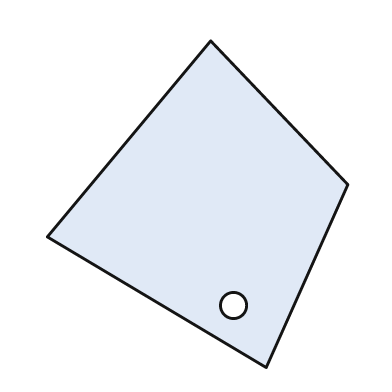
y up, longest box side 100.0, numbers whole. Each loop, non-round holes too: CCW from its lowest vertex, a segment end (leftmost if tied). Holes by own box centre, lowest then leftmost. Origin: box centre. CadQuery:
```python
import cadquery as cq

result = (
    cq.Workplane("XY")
    .moveTo(21.0, -50.0)
    .lineTo(46.0, 6.0)
    .lineTo(4.0, 50.0)
    .lineTo(-46.0, -10.0)
    .close()
    .moveTo(11.0, -31.0)
    .circle(4.0)
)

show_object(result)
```